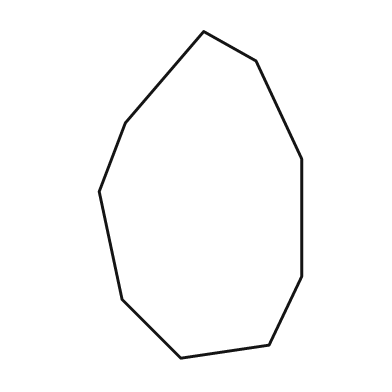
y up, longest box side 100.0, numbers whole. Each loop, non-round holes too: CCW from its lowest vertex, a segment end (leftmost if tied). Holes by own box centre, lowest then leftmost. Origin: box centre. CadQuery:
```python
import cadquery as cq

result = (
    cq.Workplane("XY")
    .moveTo(-6.0, -50.0)
    .lineTo(21.0, -46.0)
    .lineTo(31.0, -25.0)
    .lineTo(31.0, 11.0)
    .lineTo(17.0, 41.0)
    .lineTo(1.0, 50.0)
    .lineTo(-23.0, 22.0)
    .lineTo(-31.0, 1.0)
    .lineTo(-24.0, -32.0)
    .close()
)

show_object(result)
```